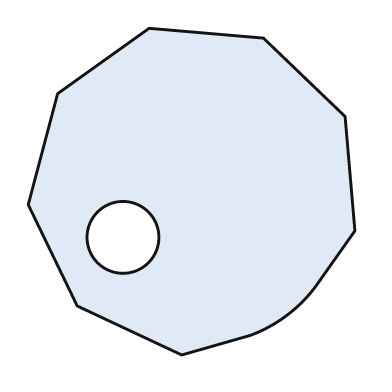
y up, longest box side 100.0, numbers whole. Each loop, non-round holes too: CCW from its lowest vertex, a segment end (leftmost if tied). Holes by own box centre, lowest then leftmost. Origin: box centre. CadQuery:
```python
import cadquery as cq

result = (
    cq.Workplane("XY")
    .moveTo(-3.0, -50.0)
    .lineTo(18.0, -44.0)
    .threePointArc((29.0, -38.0), (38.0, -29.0))
    .lineTo(50.0, -12.0)
    .lineTo(47.0, 23.0)
    .lineTo(22.0, 47.0)
    .lineTo(-13.0, 50.0)
    .lineTo(-41.0, 30.0)
    .lineTo(-50.0, -4.0)
    .lineTo(-35.0, -35.0)
    .close()
    .moveTo(-21.0, -14.0)
    .circle(11.0)
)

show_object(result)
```